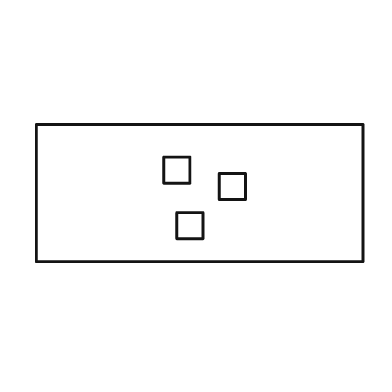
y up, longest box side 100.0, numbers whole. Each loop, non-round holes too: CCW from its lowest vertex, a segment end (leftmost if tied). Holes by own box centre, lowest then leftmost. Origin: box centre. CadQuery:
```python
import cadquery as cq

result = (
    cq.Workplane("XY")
    .moveTo(-50.0, -21.0)
    .lineTo(50.0, -21.0)
    .lineTo(50.0, 21.0)
    .lineTo(-50.0, 21.0)
    .close()
    .moveTo(-7.0, -14.0)
    .lineTo(1.0, -14.0)
    .lineTo(1.0, -6.0)
    .lineTo(-7.0, -6.0)
    .close()
    .moveTo(6.0, -2.0)
    .lineTo(14.0, -2.0)
    .lineTo(14.0, 6.0)
    .lineTo(6.0, 6.0)
    .close()
    .moveTo(-11.0, 3.0)
    .lineTo(-3.0, 3.0)
    .lineTo(-3.0, 11.0)
    .lineTo(-11.0, 11.0)
    .close()
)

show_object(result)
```